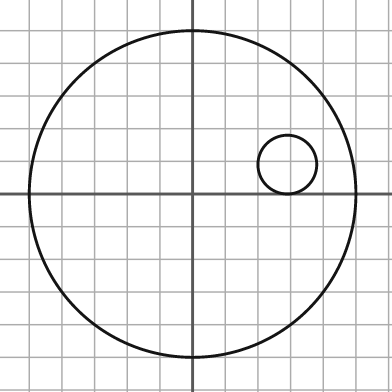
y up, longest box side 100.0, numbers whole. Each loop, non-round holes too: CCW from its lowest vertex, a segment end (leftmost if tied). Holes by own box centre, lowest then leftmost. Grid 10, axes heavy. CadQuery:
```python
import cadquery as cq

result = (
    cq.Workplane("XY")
    .moveTo(0.0, 0.0)
    .circle(50.0)
    .moveTo(29.0, 9.0)
    .circle(9.0)
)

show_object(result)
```